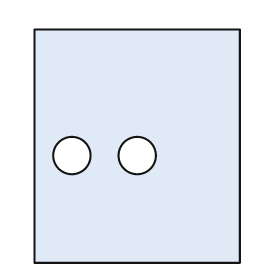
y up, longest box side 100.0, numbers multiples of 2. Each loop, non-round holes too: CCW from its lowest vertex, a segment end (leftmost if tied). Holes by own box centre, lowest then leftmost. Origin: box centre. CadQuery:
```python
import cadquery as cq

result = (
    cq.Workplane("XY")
    .moveTo(-44.0, -50.0)
    .lineTo(44.0, -50.0)
    .lineTo(44.0, 50.0)
    .lineTo(-44.0, 50.0)
    .close()
    .moveTo(-28.0, -4.0)
    .circle(8.0)
    .moveTo(0.0, -4.0)
    .circle(8.0)
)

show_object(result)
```